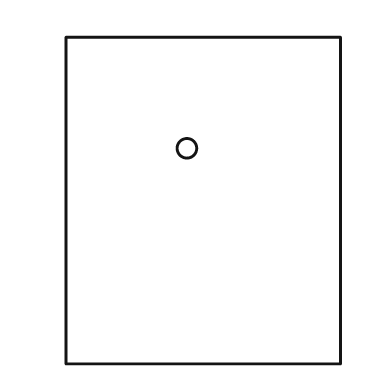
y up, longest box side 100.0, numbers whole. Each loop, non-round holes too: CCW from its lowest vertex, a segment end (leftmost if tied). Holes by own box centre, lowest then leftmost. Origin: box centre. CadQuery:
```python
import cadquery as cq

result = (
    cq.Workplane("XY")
    .moveTo(-42.0, -50.0)
    .lineTo(42.0, -50.0)
    .lineTo(42.0, 50.0)
    .lineTo(-42.0, 50.0)
    .close()
    .moveTo(-5.0, 16.0)
    .circle(3.0)
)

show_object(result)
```